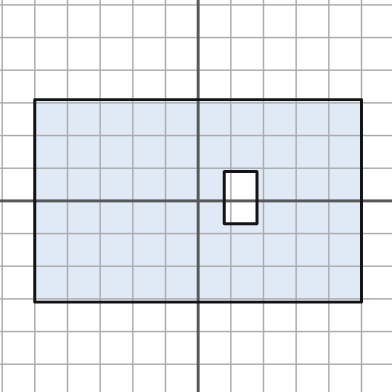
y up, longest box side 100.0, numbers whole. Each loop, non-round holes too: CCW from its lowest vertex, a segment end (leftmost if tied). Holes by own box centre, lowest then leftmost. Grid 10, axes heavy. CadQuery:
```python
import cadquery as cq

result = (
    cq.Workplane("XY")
    .moveTo(-50.0, -31.0)
    .lineTo(50.0, -31.0)
    .lineTo(50.0, 31.0)
    .lineTo(-50.0, 31.0)
    .close()
    .moveTo(8.0, -7.0)
    .lineTo(18.0, -7.0)
    .lineTo(18.0, 9.0)
    .lineTo(8.0, 9.0)
    .close()
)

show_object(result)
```